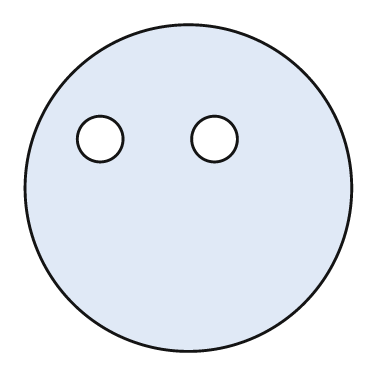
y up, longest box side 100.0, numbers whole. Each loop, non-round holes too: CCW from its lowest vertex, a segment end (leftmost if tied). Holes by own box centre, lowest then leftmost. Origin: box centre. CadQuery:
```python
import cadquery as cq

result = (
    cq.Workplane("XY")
    .moveTo(0.0, 0.0)
    .circle(50.0)
    .moveTo(-27.0, 15.0)
    .circle(7.0)
    .moveTo(8.0, 15.0)
    .circle(7.0)
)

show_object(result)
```